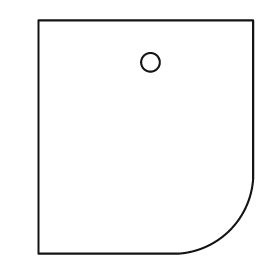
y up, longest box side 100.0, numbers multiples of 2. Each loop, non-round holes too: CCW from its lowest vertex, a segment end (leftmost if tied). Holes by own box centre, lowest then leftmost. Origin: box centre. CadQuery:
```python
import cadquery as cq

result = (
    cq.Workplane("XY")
    .moveTo(-46.0, -50.0)
    .lineTo(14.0, -50.0)
    .threePointArc((36.0, -40.0), (46.0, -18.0))
    .lineTo(46.0, 50.0)
    .lineTo(-46.0, 50.0)
    .close()
    .moveTo(2.0, 32.0)
    .circle(4.0)
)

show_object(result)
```